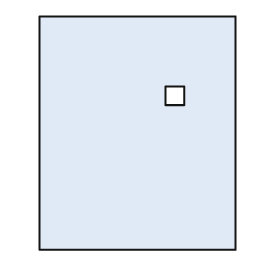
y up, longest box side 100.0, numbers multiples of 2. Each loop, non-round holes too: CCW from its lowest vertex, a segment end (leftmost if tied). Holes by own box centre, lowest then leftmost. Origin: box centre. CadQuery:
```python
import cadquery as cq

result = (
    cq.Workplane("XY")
    .moveTo(-42.0, -50.0)
    .lineTo(42.0, -50.0)
    .lineTo(42.0, 50.0)
    .lineTo(-42.0, 50.0)
    .close()
    .moveTo(12.0, 12.0)
    .lineTo(20.0, 12.0)
    .lineTo(20.0, 20.0)
    .lineTo(12.0, 20.0)
    .close()
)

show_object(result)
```